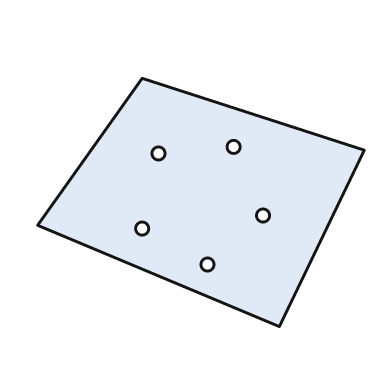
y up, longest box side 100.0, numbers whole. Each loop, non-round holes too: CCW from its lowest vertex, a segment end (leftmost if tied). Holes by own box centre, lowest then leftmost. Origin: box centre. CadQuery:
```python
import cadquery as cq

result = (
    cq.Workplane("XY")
    .moveTo(24.0, -38.0)
    .lineTo(50.0, 16.0)
    .lineTo(-18.0, 38.0)
    .lineTo(-50.0, -7.0)
    .close()
    .moveTo(2.0, -19.0)
    .circle(2.0)
    .moveTo(-18.0, -8.0)
    .circle(2.0)
    .moveTo(19.0, -4.0)
    .circle(2.0)
    .moveTo(-13.0, 15.0)
    .circle(2.0)
    .moveTo(10.0, 17.0)
    .circle(2.0)
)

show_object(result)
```